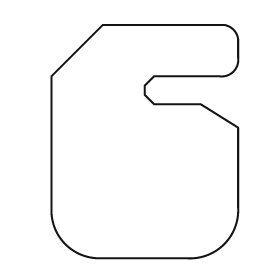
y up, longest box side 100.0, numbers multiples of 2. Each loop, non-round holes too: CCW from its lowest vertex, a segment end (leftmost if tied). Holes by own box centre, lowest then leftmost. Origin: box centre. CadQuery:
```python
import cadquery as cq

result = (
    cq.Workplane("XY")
    .moveTo(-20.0, -50.0)
    .lineTo(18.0, -50.0)
    .threePointArc((34.0, -44.0), (40.0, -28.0))
    .lineTo(40.0, 6.0)
    .lineTo(24.0, 16.0)
    .lineTo(4.0, 16.0)
    .lineTo(0.0, 20.0)
    .lineTo(0.0, 24.0)
    .lineTo(4.0, 28.0)
    .lineTo(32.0, 28.0)
    .threePointArc((38.0, 30.0), (40.0, 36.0))
    .lineTo(40.0, 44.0)
    .threePointArc((38.0, 48.0), (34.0, 50.0))
    .lineTo(-18.0, 50.0)
    .lineTo(-40.0, 28.0)
    .lineTo(-40.0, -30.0)
    .threePointArc((-34.0, -44.0), (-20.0, -50.0))
    .close()
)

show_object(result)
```